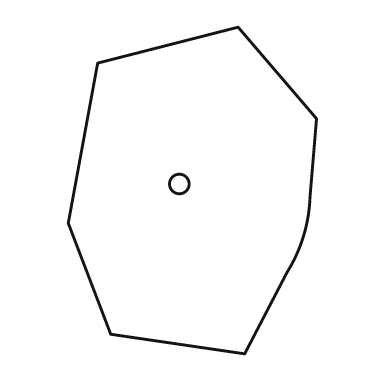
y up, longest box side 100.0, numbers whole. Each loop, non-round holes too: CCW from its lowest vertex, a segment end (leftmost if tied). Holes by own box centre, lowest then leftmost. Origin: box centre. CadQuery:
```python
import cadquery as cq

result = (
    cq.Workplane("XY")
    .moveTo(16.0, -50.0)
    .lineTo(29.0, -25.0)
    .threePointArc((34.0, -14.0), (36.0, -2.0))
    .lineTo(38.0, 22.0)
    .lineTo(14.0, 50.0)
    .lineTo(-29.0, 39.0)
    .lineTo(-38.0, -10.0)
    .lineTo(-25.0, -44.0)
    .close()
    .moveTo(-4.0, 2.0)
    .circle(3.0)
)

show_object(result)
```